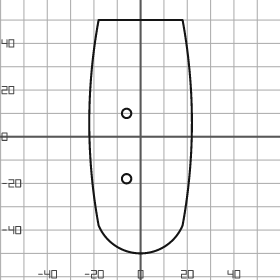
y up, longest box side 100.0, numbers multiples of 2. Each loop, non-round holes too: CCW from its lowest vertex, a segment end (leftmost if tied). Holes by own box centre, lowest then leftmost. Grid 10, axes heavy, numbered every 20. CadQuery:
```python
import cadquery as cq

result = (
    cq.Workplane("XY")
    .moveTo(-18.0, -38.0)
    .threePointArc((0.0, -50.0), (18.0, -38.0))
    .threePointArc((22.0, 6.0), (18.0, 50.0))
    .lineTo(-18.0, 50.0)
    .threePointArc((-22.0, 6.0), (-18.0, -38.0))
    .close()
    .moveTo(-6.0, -18.0)
    .circle(2.0)
    .moveTo(-6.0, 10.0)
    .circle(2.0)
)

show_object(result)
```